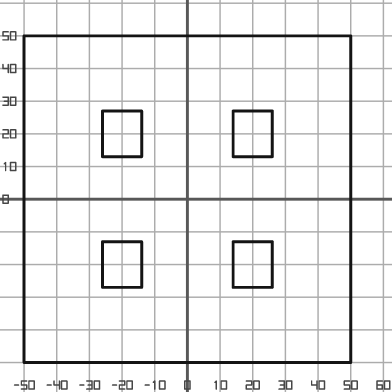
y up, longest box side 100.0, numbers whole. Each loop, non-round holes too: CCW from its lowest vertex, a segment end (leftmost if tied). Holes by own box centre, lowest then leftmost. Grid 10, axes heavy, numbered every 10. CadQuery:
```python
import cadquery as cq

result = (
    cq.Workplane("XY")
    .moveTo(-50.0, -50.0)
    .lineTo(50.0, -50.0)
    .lineTo(50.0, 50.0)
    .lineTo(-50.0, 50.0)
    .close()
    .moveTo(-26.0, -27.0)
    .lineTo(-14.0, -27.0)
    .lineTo(-14.0, -13.0)
    .lineTo(-26.0, -13.0)
    .close()
    .moveTo(14.0, -27.0)
    .lineTo(26.0, -27.0)
    .lineTo(26.0, -13.0)
    .lineTo(14.0, -13.0)
    .close()
    .moveTo(-26.0, 13.0)
    .lineTo(-14.0, 13.0)
    .lineTo(-14.0, 27.0)
    .lineTo(-26.0, 27.0)
    .close()
    .moveTo(14.0, 13.0)
    .lineTo(26.0, 13.0)
    .lineTo(26.0, 27.0)
    .lineTo(14.0, 27.0)
    .close()
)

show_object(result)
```